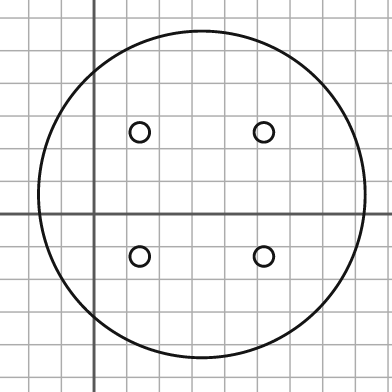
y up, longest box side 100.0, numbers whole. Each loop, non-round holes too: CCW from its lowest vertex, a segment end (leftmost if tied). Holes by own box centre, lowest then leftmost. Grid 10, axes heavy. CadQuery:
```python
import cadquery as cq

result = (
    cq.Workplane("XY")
    .moveTo(33.0, 6.0)
    .circle(50.0)
    .moveTo(14.0, -13.0)
    .circle(3.0)
    .moveTo(52.0, -13.0)
    .circle(3.0)
    .moveTo(14.0, 25.0)
    .circle(3.0)
    .moveTo(52.0, 25.0)
    .circle(3.0)
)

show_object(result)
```